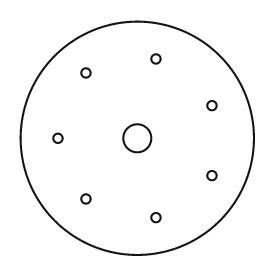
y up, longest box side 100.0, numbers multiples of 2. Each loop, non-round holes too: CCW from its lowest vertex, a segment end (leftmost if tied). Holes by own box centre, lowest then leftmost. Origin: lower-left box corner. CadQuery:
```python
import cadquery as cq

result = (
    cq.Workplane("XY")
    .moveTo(50.0, 50.0)
    .circle(50.0)
    .moveTo(58.0, 16.0)
    .circle(2.0)
    .moveTo(28.0, 24.0)
    .circle(2.0)
    .moveTo(82.0, 34.0)
    .circle(2.0)
    .moveTo(16.0, 50.0)
    .circle(2.0)
    .moveTo(50.0, 50.0)
    .circle(6.0)
    .moveTo(82.0, 64.0)
    .circle(2.0)
    .moveTo(28.0, 78.0)
    .circle(2.0)
    .moveTo(58.0, 84.0)
    .circle(2.0)
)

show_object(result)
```